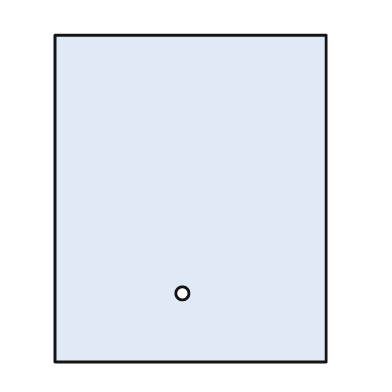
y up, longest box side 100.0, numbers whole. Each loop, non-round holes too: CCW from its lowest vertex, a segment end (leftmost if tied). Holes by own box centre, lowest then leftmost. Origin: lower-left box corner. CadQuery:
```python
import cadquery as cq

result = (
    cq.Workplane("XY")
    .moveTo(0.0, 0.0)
    .lineTo(83.0, 0.0)
    .lineTo(83.0, 100.0)
    .lineTo(0.0, 100.0)
    .close()
    .moveTo(39.0, 21.0)
    .circle(2.0)
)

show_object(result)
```